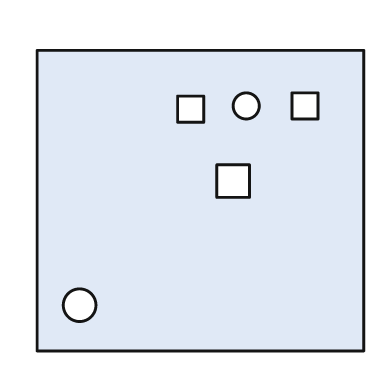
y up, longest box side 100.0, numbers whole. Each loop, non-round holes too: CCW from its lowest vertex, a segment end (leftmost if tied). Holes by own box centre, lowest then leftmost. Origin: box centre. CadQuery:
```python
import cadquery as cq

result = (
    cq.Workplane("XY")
    .moveTo(-50.0, -46.0)
    .lineTo(50.0, -46.0)
    .lineTo(50.0, 46.0)
    .lineTo(-50.0, 46.0)
    .close()
    .moveTo(-37.0, -32.0)
    .circle(5.0)
    .moveTo(5.0, 1.0)
    .lineTo(15.0, 1.0)
    .lineTo(15.0, 11.0)
    .lineTo(5.0, 11.0)
    .close()
    .moveTo(-7.0, 24.0)
    .lineTo(1.0, 24.0)
    .lineTo(1.0, 32.0)
    .lineTo(-7.0, 32.0)
    .close()
    .moveTo(14.0, 29.0)
    .circle(4.0)
    .moveTo(28.0, 25.0)
    .lineTo(36.0, 25.0)
    .lineTo(36.0, 33.0)
    .lineTo(28.0, 33.0)
    .close()
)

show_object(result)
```